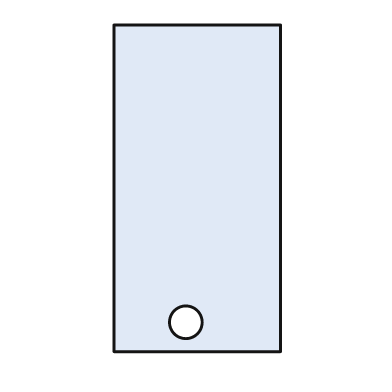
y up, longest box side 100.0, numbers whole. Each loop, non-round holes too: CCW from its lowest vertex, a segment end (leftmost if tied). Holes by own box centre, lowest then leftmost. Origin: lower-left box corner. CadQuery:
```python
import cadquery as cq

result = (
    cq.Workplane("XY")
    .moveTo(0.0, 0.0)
    .lineTo(51.0, 0.0)
    .lineTo(51.0, 100.0)
    .lineTo(0.0, 100.0)
    .close()
    .moveTo(22.0, 9.0)
    .circle(5.0)
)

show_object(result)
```